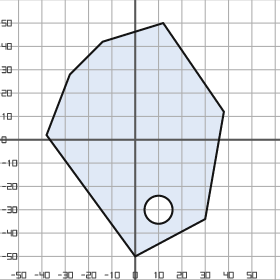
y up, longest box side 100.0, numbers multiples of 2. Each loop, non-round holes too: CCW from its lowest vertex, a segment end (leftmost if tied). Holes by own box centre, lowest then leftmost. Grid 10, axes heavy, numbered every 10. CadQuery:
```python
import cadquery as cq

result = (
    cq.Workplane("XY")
    .moveTo(0.0, -50.0)
    .lineTo(30.0, -34.0)
    .lineTo(38.0, 12.0)
    .lineTo(12.0, 50.0)
    .lineTo(-14.0, 42.0)
    .lineTo(-28.0, 28.0)
    .lineTo(-38.0, 2.0)
    .close()
    .moveTo(10.0, -30.0)
    .circle(6.0)
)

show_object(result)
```